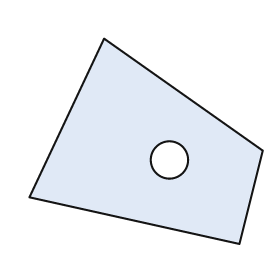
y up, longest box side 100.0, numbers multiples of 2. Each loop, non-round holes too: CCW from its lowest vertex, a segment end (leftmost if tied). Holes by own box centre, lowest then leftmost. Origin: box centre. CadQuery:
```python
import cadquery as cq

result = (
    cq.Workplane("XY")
    .moveTo(40.0, -44.0)
    .lineTo(50.0, -4.0)
    .lineTo(-18.0, 44.0)
    .lineTo(-50.0, -24.0)
    .close()
    .moveTo(10.0, -8.0)
    .circle(8.0)
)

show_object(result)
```